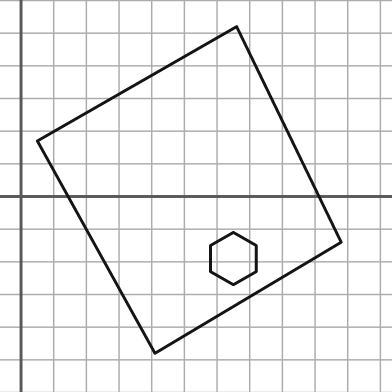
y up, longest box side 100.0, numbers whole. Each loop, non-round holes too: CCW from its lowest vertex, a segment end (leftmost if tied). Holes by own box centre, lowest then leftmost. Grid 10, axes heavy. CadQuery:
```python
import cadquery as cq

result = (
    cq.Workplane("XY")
    .moveTo(41.0, -48.0)
    .lineTo(98.0, -14.0)
    .lineTo(66.0, 52.0)
    .lineTo(5.0, 17.0)
    .close()
    .moveTo(65.0, -27.0)
    .lineTo(72.0, -23.0)
    .lineTo(72.0, -15.0)
    .lineTo(65.0, -11.0)
    .lineTo(58.0, -15.0)
    .lineTo(58.0, -23.0)
    .close()
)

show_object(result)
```